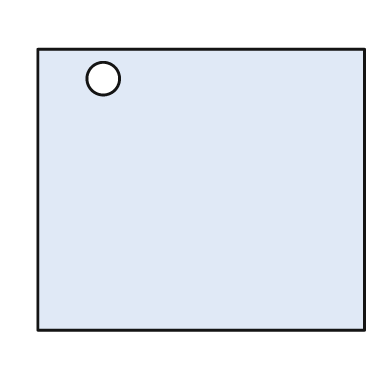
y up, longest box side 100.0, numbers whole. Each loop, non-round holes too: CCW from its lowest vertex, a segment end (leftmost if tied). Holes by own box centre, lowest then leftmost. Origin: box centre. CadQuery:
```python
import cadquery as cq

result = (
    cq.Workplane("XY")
    .moveTo(-50.0, -43.0)
    .lineTo(50.0, -43.0)
    .lineTo(50.0, 43.0)
    .lineTo(-50.0, 43.0)
    .close()
    .moveTo(-30.0, 34.0)
    .circle(5.0)
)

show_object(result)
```